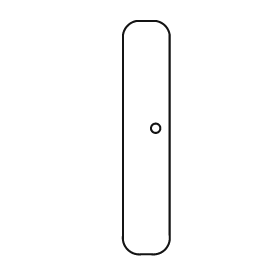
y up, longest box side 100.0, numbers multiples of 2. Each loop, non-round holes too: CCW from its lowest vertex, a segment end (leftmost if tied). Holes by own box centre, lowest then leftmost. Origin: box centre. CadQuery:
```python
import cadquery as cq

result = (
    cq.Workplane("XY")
    .moveTo(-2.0, -50.0)
    .lineTo(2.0, -50.0)
    .threePointArc((8.0, -48.0), (10.0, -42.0))
    .lineTo(10.0, 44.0)
    .threePointArc((8.0, 48.0), (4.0, 50.0))
    .lineTo(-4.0, 50.0)
    .threePointArc((-8.0, 48.0), (-10.0, 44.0))
    .lineTo(-10.0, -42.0)
    .threePointArc((-8.0, -48.0), (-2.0, -50.0))
    .close()
    .moveTo(4.0, 4.0)
    .circle(2.0)
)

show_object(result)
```